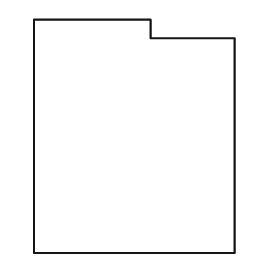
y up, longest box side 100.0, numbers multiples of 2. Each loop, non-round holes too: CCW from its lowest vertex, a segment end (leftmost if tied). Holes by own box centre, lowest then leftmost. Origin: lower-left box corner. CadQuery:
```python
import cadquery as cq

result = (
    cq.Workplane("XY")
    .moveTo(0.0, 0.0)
    .lineTo(86.0, 0.0)
    .lineTo(86.0, 92.0)
    .lineTo(50.0, 92.0)
    .lineTo(50.0, 100.0)
    .lineTo(0.0, 100.0)
    .close()
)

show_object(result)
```